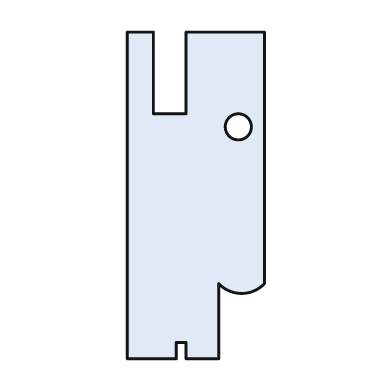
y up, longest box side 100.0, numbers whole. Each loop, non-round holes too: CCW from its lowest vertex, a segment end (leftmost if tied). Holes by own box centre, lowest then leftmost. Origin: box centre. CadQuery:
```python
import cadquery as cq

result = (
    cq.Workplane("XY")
    .moveTo(-21.0, -50.0)
    .lineTo(-6.0, -50.0)
    .lineTo(-6.0, -45.0)
    .lineTo(-3.0, -45.0)
    .lineTo(-3.0, -50.0)
    .lineTo(7.0, -50.0)
    .lineTo(7.0, -27.0)
    .threePointArc((14.0, -30.0), (21.0, -27.0))
    .lineTo(21.0, 50.0)
    .lineTo(-3.0, 50.0)
    .lineTo(-3.0, 25.0)
    .lineTo(-13.0, 25.0)
    .lineTo(-13.0, 50.0)
    .lineTo(-21.0, 50.0)
    .close()
    .moveTo(13.0, 21.0)
    .circle(4.0)
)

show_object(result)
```